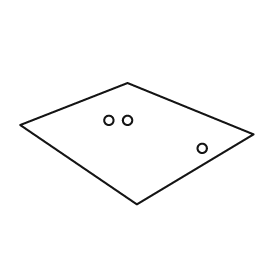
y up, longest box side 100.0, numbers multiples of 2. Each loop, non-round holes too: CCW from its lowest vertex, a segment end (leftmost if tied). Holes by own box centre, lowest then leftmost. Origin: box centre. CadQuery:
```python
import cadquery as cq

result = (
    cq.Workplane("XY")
    .moveTo(0.0, -26.0)
    .lineTo(50.0, 4.0)
    .lineTo(-4.0, 26.0)
    .lineTo(-50.0, 8.0)
    .close()
    .moveTo(28.0, -2.0)
    .circle(2.0)
    .moveTo(-12.0, 10.0)
    .circle(2.0)
    .moveTo(-4.0, 10.0)
    .circle(2.0)
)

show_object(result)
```